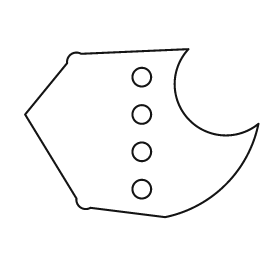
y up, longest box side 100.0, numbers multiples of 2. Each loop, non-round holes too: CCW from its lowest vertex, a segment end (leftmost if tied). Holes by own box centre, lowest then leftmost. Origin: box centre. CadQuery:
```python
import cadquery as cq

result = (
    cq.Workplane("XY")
    .moveTo(10.0, -36.0)
    .threePointArc((36.0, -22.0), (50.0, 4.0))
    .threePointArc((20.0, 6.0), (20.0, 36.0))
    .lineTo(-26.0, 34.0)
    .threePointArc((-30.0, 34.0), (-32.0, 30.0))
    .lineTo(-50.0, 8.0)
    .lineTo(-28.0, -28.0)
    .threePointArc((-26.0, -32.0), (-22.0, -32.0))
    .close()
    .moveTo(0.0, -24.0)
    .circle(4.0)
    .moveTo(0.0, -8.0)
    .circle(4.0)
    .moveTo(0.0, 8.0)
    .circle(4.0)
    .moveTo(0.0, 24.0)
    .circle(4.0)
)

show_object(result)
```